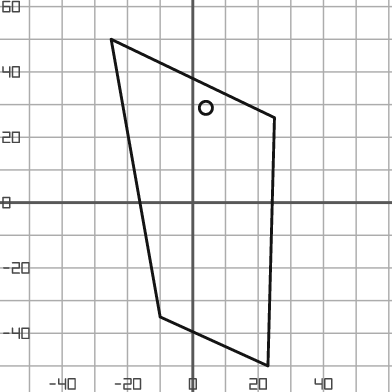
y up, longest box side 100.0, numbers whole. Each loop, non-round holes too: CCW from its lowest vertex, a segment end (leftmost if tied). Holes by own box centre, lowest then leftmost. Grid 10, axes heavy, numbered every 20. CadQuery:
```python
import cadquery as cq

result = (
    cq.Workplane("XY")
    .moveTo(23.0, -50.0)
    .lineTo(25.0, 26.0)
    .lineTo(-25.0, 50.0)
    .lineTo(-10.0, -35.0)
    .close()
    .moveTo(4.0, 29.0)
    .circle(2.0)
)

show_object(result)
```